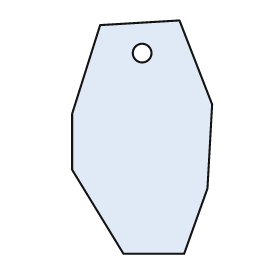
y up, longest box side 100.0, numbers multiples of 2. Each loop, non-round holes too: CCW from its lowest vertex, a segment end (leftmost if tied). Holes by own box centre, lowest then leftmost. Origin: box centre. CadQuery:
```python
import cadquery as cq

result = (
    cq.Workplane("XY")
    .moveTo(-8.0, -50.0)
    .lineTo(18.0, -50.0)
    .lineTo(28.0, -22.0)
    .lineTo(30.0, 14.0)
    .lineTo(16.0, 50.0)
    .lineTo(-18.0, 48.0)
    .lineTo(-30.0, 10.0)
    .lineTo(-30.0, -14.0)
    .close()
    .moveTo(0.0, 36.0)
    .circle(4.0)
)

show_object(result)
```